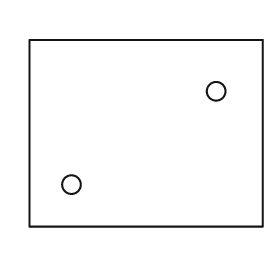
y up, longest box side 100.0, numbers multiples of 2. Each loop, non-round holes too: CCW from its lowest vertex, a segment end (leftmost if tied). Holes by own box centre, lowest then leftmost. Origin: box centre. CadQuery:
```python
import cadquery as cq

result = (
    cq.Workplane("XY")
    .moveTo(-50.0, -40.0)
    .lineTo(50.0, -40.0)
    .lineTo(50.0, 40.0)
    .lineTo(-50.0, 40.0)
    .close()
    .moveTo(-32.0, -22.0)
    .circle(4.0)
    .moveTo(30.0, 18.0)
    .circle(4.0)
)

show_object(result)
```